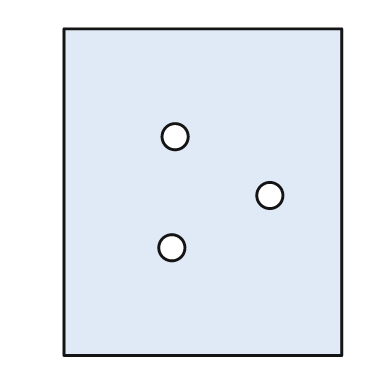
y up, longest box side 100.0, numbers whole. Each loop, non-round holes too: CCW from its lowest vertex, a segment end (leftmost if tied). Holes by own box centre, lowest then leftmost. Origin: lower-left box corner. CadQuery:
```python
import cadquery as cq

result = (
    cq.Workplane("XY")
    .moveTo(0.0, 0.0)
    .lineTo(85.0, 0.0)
    .lineTo(85.0, 100.0)
    .lineTo(0.0, 100.0)
    .close()
    .moveTo(33.0, 33.0)
    .circle(4.0)
    .moveTo(63.0, 49.0)
    .circle(4.0)
    .moveTo(34.0, 67.0)
    .circle(4.0)
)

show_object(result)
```